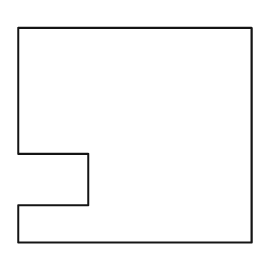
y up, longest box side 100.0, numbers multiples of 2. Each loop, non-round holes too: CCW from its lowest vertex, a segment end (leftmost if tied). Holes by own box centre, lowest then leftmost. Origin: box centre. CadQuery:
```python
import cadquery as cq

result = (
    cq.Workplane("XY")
    .moveTo(-50.0, -46.0)
    .lineTo(50.0, -46.0)
    .lineTo(50.0, 46.0)
    .lineTo(-50.0, 46.0)
    .lineTo(-50.0, -8.0)
    .lineTo(-20.0, -8.0)
    .lineTo(-20.0, -30.0)
    .lineTo(-50.0, -30.0)
    .close()
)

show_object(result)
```